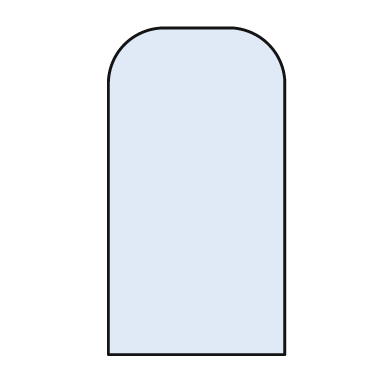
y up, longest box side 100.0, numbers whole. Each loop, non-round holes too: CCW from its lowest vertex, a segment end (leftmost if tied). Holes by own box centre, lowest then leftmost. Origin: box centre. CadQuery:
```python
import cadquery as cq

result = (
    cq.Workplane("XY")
    .moveTo(-27.0, -50.0)
    .lineTo(27.0, -50.0)
    .lineTo(27.0, 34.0)
    .threePointArc((22.0, 45.0), (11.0, 50.0))
    .lineTo(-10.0, 50.0)
    .threePointArc((-22.0, 45.0), (-27.0, 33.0))
    .close()
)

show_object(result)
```